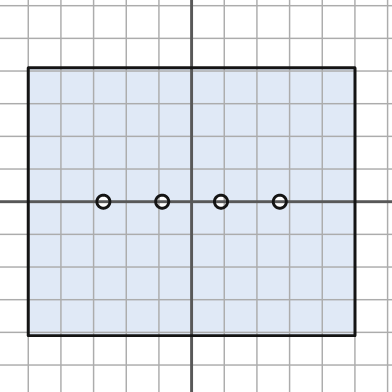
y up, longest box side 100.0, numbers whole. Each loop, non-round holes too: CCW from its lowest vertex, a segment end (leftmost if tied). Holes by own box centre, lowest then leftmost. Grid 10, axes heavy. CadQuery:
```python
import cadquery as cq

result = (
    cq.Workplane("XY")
    .moveTo(-50.0, -41.0)
    .lineTo(50.0, -41.0)
    .lineTo(50.0, 41.0)
    .lineTo(-50.0, 41.0)
    .close()
    .moveTo(-27.0, 0.0)
    .circle(2.0)
    .moveTo(-9.0, 0.0)
    .circle(2.0)
    .moveTo(9.0, 0.0)
    .circle(2.0)
    .moveTo(27.0, 0.0)
    .circle(2.0)
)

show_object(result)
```